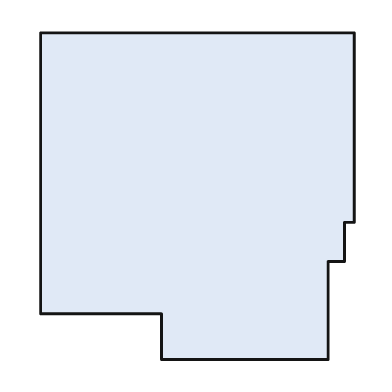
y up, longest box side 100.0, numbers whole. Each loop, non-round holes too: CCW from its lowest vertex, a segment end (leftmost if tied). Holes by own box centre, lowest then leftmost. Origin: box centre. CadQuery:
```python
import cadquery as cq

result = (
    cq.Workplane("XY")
    .moveTo(-11.0, -50.0)
    .lineTo(40.0, -50.0)
    .lineTo(40.0, -20.0)
    .lineTo(45.0, -20.0)
    .lineTo(45.0, -8.0)
    .lineTo(48.0, -8.0)
    .lineTo(48.0, 50.0)
    .lineTo(-48.0, 50.0)
    .lineTo(-48.0, -36.0)
    .lineTo(-11.0, -36.0)
    .close()
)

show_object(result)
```